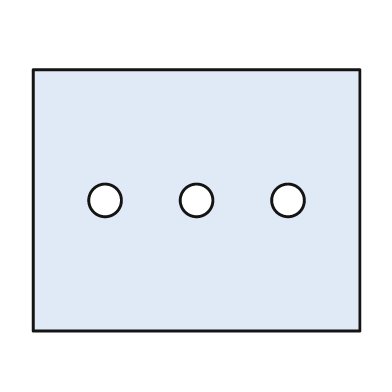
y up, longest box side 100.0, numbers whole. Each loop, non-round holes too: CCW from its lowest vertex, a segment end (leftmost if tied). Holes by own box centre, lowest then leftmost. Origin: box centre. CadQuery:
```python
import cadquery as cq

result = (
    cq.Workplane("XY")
    .moveTo(-50.0, -40.0)
    .lineTo(50.0, -40.0)
    .lineTo(50.0, 40.0)
    .lineTo(-50.0, 40.0)
    .close()
    .moveTo(-28.0, 0.0)
    .circle(5.0)
    .moveTo(0.0, 0.0)
    .circle(5.0)
    .moveTo(28.0, 0.0)
    .circle(5.0)
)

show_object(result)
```